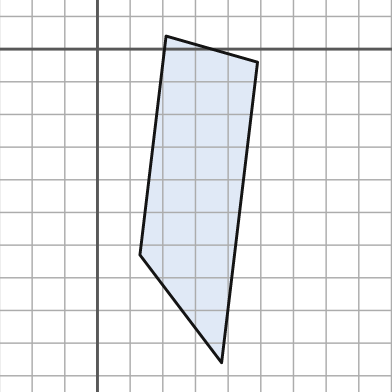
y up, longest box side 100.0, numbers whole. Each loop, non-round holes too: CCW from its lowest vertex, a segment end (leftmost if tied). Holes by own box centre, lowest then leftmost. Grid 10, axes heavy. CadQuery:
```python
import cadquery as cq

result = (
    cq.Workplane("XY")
    .moveTo(38.0, -96.0)
    .lineTo(49.0, -4.0)
    .lineTo(21.0, 4.0)
    .lineTo(13.0, -63.0)
    .close()
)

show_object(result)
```